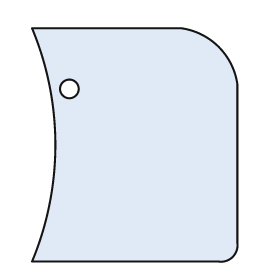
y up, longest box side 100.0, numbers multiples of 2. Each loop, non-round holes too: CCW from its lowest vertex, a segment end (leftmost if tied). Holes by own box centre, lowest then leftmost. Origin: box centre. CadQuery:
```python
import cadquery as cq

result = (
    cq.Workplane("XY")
    .moveTo(-44.0, -50.0)
    .lineTo(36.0, -50.0)
    .threePointArc((42.0, -48.0), (44.0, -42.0))
    .lineTo(44.0, 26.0)
    .threePointArc((36.0, 42.0), (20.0, 50.0))
    .lineTo(-44.0, 50.0)
    .threePointArc((-34.0, 0.0), (-44.0, -50.0))
    .close()
    .moveTo(-28.0, 24.0)
    .circle(4.0)
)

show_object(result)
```